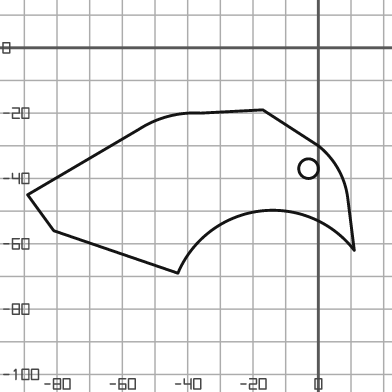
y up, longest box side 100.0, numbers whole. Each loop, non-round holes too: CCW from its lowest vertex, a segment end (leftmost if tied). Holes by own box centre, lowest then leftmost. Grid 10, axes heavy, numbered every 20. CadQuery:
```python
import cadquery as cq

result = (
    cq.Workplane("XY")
    .moveTo(-43.0, -69.0)
    .threePointArc((-18.0, -50.0), (11.0, -62.0))
    .lineTo(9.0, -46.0)
    .threePointArc((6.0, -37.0), (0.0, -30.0))
    .lineTo(-17.0, -19.0)
    .lineTo(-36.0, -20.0)
    .threePointArc((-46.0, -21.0), (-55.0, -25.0))
    .lineTo(-89.0, -45.0)
    .lineTo(-81.0, -56.0)
    .close()
    .moveTo(-3.0, -37.0)
    .circle(3.0)
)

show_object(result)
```